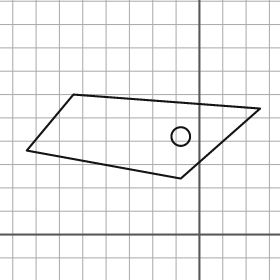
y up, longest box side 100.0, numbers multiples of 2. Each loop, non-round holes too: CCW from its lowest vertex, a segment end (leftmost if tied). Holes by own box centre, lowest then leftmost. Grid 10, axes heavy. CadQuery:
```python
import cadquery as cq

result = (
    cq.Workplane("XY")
    .moveTo(-8.0, 24.0)
    .lineTo(26.0, 54.0)
    .lineTo(-54.0, 60.0)
    .lineTo(-74.0, 36.0)
    .close()
    .moveTo(-8.0, 42.0)
    .circle(4.0)
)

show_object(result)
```